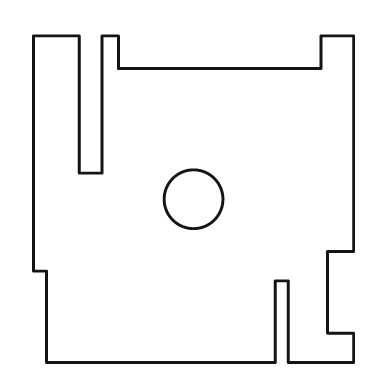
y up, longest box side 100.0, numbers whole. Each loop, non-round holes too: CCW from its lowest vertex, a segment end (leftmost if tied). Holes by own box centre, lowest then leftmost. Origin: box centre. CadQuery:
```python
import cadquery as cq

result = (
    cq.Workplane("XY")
    .moveTo(-45.0, -50.0)
    .lineTo(25.0, -50.0)
    .lineTo(25.0, -25.0)
    .lineTo(29.0, -25.0)
    .lineTo(29.0, -50.0)
    .lineTo(49.0, -50.0)
    .lineTo(49.0, -41.0)
    .lineTo(41.0, -41.0)
    .lineTo(41.0, -16.0)
    .lineTo(49.0, -16.0)
    .lineTo(49.0, 50.0)
    .lineTo(39.0, 50.0)
    .lineTo(39.0, 40.0)
    .lineTo(-23.0, 40.0)
    .lineTo(-23.0, 50.0)
    .lineTo(-28.0, 50.0)
    .lineTo(-28.0, 8.0)
    .lineTo(-35.0, 8.0)
    .lineTo(-35.0, 50.0)
    .lineTo(-49.0, 50.0)
    .lineTo(-49.0, -22.0)
    .lineTo(-45.0, -22.0)
    .close()
    .moveTo(0.0, 0.0)
    .circle(9.0)
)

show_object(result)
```